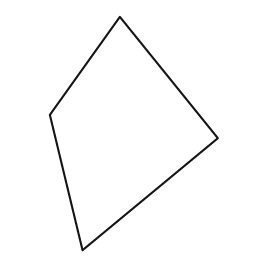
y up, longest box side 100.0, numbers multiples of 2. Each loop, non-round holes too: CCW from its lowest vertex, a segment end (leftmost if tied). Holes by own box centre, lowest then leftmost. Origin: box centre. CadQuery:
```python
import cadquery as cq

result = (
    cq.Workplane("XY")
    .moveTo(-22.0, -50.0)
    .lineTo(36.0, -2.0)
    .lineTo(-6.0, 50.0)
    .lineTo(-36.0, 8.0)
    .close()
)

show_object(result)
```